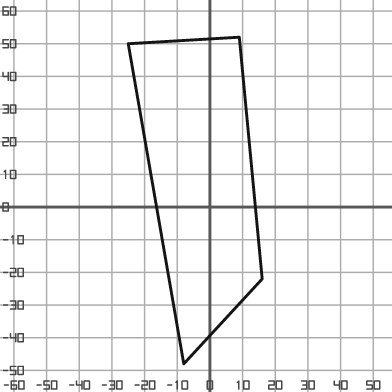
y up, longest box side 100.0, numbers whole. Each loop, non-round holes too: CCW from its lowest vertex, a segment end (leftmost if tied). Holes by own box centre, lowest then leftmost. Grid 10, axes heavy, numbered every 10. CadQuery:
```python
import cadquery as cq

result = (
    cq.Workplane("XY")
    .moveTo(-8.0, -48.0)
    .lineTo(16.0, -22.0)
    .lineTo(9.0, 52.0)
    .lineTo(-25.0, 50.0)
    .close()
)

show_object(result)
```